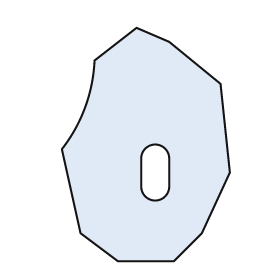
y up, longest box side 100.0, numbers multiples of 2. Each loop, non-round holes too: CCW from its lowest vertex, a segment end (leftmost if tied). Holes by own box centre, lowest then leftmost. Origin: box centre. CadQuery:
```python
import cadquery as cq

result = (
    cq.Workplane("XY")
    .moveTo(-12.0, -50.0)
    .lineTo(12.0, -50.0)
    .lineTo(24.0, -38.0)
    .lineTo(36.0, -12.0)
    .lineTo(32.0, 26.0)
    .lineTo(10.0, 44.0)
    .lineTo(-4.0, 50.0)
    .lineTo(-22.0, 36.0)
    .threePointArc((-26.0, 16.0), (-36.0, -2.0))
    .lineTo(-28.0, -38.0)
    .close()
    .moveTo(-2.0, -18.0)
    .threePointArc((4.0, -24.0), (10.0, -18.0))
    .lineTo(10.0, -6.0)
    .threePointArc((4.0, 0.0), (-2.0, -6.0))
    .close()
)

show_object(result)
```